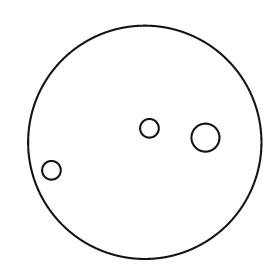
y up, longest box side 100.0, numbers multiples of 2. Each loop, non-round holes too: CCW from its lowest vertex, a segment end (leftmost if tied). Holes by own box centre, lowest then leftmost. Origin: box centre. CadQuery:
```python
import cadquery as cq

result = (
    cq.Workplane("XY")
    .moveTo(0.0, 0.0)
    .circle(50.0)
    .moveTo(-40.0, -12.0)
    .circle(4.0)
    .moveTo(26.0, 2.0)
    .circle(6.0)
    .moveTo(2.0, 6.0)
    .circle(4.0)
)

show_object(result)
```